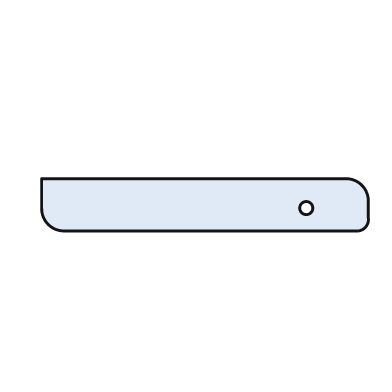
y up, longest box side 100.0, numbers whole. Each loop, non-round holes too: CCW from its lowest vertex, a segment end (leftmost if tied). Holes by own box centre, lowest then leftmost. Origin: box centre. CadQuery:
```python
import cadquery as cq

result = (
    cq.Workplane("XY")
    .moveTo(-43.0, -8.0)
    .lineTo(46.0, -8.0)
    .threePointArc((49.0, -7.0), (50.0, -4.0))
    .lineTo(50.0, 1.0)
    .threePointArc((48.0, 6.0), (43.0, 8.0))
    .lineTo(-50.0, 8.0)
    .lineTo(-50.0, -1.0)
    .threePointArc((-48.0, -6.0), (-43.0, -8.0))
    .close()
    .moveTo(31.0, -1.0)
    .circle(2.0)
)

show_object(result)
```